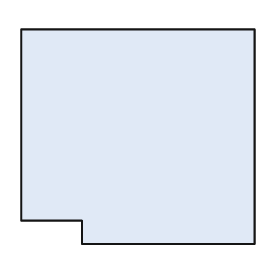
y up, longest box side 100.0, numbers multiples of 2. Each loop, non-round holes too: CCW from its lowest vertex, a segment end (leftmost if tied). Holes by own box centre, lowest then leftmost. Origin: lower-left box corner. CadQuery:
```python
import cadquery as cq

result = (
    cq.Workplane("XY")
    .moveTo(26.0, 0.0)
    .lineTo(100.0, 0.0)
    .lineTo(100.0, 92.0)
    .lineTo(0.0, 92.0)
    .lineTo(0.0, 10.0)
    .lineTo(26.0, 10.0)
    .close()
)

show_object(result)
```